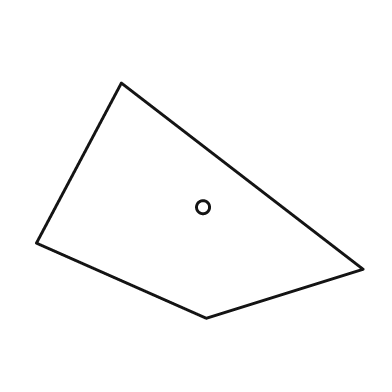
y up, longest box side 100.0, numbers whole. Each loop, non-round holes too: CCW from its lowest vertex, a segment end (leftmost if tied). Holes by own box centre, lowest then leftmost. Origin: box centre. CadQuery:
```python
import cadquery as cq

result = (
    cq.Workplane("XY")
    .moveTo(2.0, -36.0)
    .lineTo(50.0, -21.0)
    .lineTo(-24.0, 36.0)
    .lineTo(-50.0, -13.0)
    .close()
    .moveTo(1.0, -2.0)
    .circle(2.0)
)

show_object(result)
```